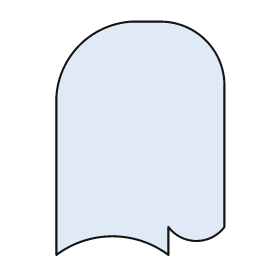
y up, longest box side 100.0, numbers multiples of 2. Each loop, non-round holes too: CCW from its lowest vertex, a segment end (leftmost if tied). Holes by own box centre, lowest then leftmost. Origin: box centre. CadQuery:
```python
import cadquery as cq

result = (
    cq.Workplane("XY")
    .moveTo(-36.0, -50.0)
    .threePointArc((-12.0, -42.0), (12.0, -50.0))
    .lineTo(12.0, -38.0)
    .threePointArc((24.0, -44.0), (36.0, -38.0))
    .lineTo(36.0, 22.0)
    .threePointArc((28.0, 42.0), (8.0, 50.0))
    .lineTo(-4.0, 50.0)
    .threePointArc((-26.0, 40.0), (-36.0, 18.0))
    .close()
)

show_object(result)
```